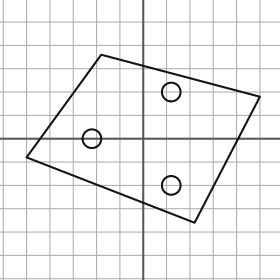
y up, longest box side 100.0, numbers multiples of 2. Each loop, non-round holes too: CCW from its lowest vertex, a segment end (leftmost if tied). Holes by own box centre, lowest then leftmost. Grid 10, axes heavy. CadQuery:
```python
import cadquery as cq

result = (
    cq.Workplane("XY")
    .moveTo(22.0, -36.0)
    .lineTo(50.0, 18.0)
    .lineTo(-18.0, 36.0)
    .lineTo(-50.0, -8.0)
    .close()
    .moveTo(12.0, -20.0)
    .circle(4.0)
    .moveTo(-22.0, 0.0)
    .circle(4.0)
    .moveTo(12.0, 20.0)
    .circle(4.0)
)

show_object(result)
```